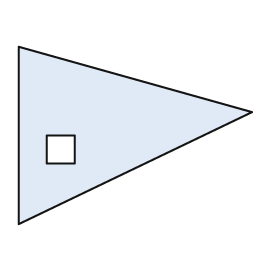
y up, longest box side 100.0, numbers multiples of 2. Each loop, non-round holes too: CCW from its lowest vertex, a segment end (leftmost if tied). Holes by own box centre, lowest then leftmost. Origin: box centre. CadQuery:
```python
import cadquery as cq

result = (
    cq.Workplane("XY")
    .moveTo(-50.0, -38.0)
    .lineTo(50.0, 10.0)
    .lineTo(-50.0, 38.0)
    .close()
    .moveTo(-38.0, -12.0)
    .lineTo(-26.0, -12.0)
    .lineTo(-26.0, 0.0)
    .lineTo(-38.0, 0.0)
    .close()
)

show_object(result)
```